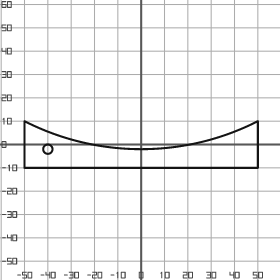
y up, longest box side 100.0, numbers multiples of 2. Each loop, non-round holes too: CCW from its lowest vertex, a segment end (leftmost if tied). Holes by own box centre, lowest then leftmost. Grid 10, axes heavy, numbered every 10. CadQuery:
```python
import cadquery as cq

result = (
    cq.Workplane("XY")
    .moveTo(-50.0, -10.0)
    .lineTo(50.0, -10.0)
    .lineTo(50.0, 10.0)
    .threePointArc((0.0, -2.0), (-50.0, 10.0))
    .close()
    .moveTo(-40.0, -2.0)
    .circle(2.0)
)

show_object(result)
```